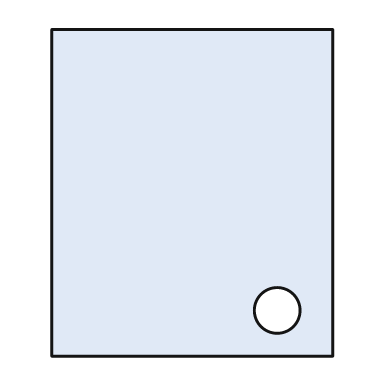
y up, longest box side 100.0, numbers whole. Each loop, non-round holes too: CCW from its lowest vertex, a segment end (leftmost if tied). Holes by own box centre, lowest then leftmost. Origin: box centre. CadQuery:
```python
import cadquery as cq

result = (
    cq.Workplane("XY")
    .moveTo(-43.0, -50.0)
    .lineTo(43.0, -50.0)
    .lineTo(43.0, 50.0)
    .lineTo(-43.0, 50.0)
    .close()
    .moveTo(26.0, -36.0)
    .circle(7.0)
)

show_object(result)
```